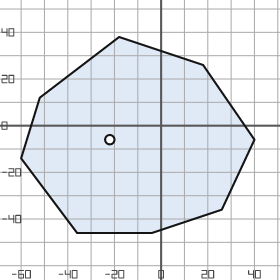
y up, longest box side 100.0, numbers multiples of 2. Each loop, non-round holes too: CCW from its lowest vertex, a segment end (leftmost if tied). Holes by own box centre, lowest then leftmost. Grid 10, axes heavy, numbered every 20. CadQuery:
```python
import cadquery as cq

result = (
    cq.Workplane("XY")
    .moveTo(-36.0, -46.0)
    .lineTo(-4.0, -46.0)
    .lineTo(26.0, -36.0)
    .lineTo(40.0, -6.0)
    .lineTo(18.0, 26.0)
    .lineTo(-18.0, 38.0)
    .lineTo(-52.0, 12.0)
    .lineTo(-60.0, -14.0)
    .close()
    .moveTo(-22.0, -6.0)
    .circle(2.0)
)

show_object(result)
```